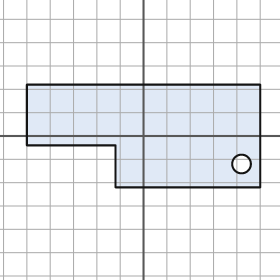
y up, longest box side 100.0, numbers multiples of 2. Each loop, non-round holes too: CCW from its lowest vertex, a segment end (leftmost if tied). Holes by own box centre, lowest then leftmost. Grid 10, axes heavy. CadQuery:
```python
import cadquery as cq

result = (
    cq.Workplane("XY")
    .moveTo(-12.0, -22.0)
    .lineTo(50.0, -22.0)
    .lineTo(50.0, 22.0)
    .lineTo(-50.0, 22.0)
    .lineTo(-50.0, -4.0)
    .lineTo(-12.0, -4.0)
    .close()
    .moveTo(42.0, -12.0)
    .circle(4.0)
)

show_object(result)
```